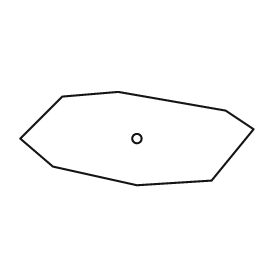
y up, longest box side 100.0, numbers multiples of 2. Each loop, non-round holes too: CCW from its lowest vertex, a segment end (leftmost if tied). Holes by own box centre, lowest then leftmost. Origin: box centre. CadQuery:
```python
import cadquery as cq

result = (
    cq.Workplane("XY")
    .moveTo(0.0, -20.0)
    .lineTo(32.0, -18.0)
    .lineTo(50.0, 4.0)
    .lineTo(38.0, 12.0)
    .lineTo(-8.0, 20.0)
    .lineTo(-32.0, 18.0)
    .lineTo(-50.0, 0.0)
    .lineTo(-36.0, -12.0)
    .close()
    .moveTo(0.0, 0.0)
    .circle(2.0)
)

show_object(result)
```